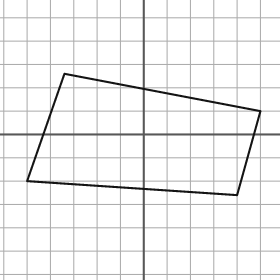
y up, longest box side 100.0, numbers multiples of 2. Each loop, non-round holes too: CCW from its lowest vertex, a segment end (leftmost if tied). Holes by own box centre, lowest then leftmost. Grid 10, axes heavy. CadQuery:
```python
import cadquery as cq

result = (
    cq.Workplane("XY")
    .moveTo(40.0, -26.0)
    .lineTo(50.0, 10.0)
    .lineTo(-34.0, 26.0)
    .lineTo(-50.0, -20.0)
    .close()
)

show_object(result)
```